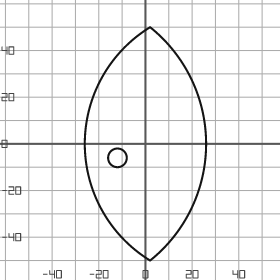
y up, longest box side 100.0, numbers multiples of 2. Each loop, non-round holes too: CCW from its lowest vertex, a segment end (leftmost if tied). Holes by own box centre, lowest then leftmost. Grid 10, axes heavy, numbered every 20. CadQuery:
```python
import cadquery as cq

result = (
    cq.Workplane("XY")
    .moveTo(2.0, -50.0)
    .threePointArc((26.0, 0.0), (2.0, 50.0))
    .threePointArc((-26.0, 0.0), (2.0, -50.0))
    .close()
    .moveTo(-12.0, -6.0)
    .circle(4.0)
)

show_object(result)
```